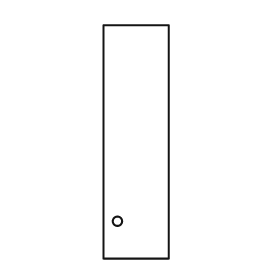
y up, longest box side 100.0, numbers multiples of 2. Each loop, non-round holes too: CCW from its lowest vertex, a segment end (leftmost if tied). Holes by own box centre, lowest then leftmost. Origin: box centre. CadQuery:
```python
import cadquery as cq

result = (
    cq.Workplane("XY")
    .moveTo(-14.0, -50.0)
    .lineTo(14.0, -50.0)
    .lineTo(14.0, 50.0)
    .lineTo(-14.0, 50.0)
    .close()
    .moveTo(-8.0, -34.0)
    .circle(2.0)
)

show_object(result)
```